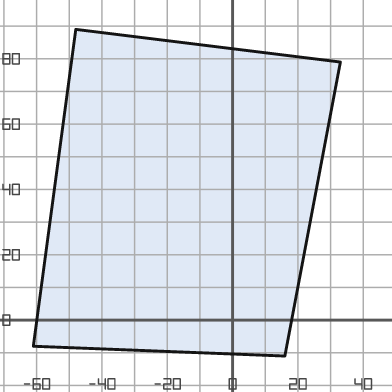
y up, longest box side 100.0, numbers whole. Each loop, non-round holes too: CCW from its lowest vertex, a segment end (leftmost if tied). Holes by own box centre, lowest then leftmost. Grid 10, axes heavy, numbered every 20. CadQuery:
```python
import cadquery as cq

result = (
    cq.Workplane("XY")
    .moveTo(16.0, -11.0)
    .lineTo(33.0, 79.0)
    .lineTo(-48.0, 89.0)
    .lineTo(-61.0, -8.0)
    .close()
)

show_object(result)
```